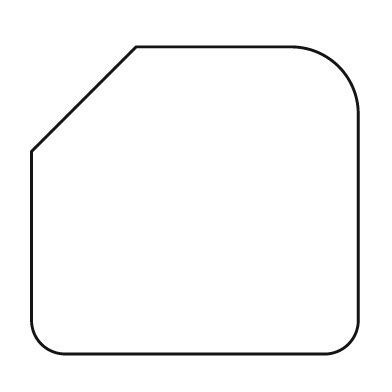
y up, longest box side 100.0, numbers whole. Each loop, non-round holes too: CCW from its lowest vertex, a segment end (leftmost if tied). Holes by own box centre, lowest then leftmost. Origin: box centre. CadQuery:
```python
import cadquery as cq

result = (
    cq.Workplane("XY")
    .moveTo(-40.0, -47.0)
    .lineTo(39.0, -47.0)
    .threePointArc((47.0, -44.0), (50.0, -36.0))
    .lineTo(50.0, 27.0)
    .threePointArc((44.0, 41.0), (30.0, 47.0))
    .lineTo(-18.0, 47.0)
    .lineTo(-50.0, 15.0)
    .lineTo(-50.0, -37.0)
    .threePointArc((-47.0, -44.0), (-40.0, -47.0))
    .close()
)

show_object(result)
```